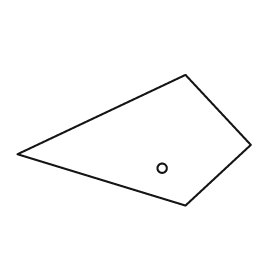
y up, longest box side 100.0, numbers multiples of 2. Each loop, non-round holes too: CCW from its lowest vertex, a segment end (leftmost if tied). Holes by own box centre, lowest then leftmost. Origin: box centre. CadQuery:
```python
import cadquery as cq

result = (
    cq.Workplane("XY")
    .moveTo(22.0, -28.0)
    .lineTo(50.0, -2.0)
    .lineTo(22.0, 28.0)
    .lineTo(-50.0, -6.0)
    .close()
    .moveTo(12.0, -12.0)
    .circle(2.0)
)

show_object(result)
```